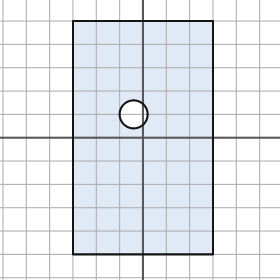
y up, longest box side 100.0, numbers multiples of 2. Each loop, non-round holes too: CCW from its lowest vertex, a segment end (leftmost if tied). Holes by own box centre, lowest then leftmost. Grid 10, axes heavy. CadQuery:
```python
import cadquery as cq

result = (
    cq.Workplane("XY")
    .moveTo(-30.0, -50.0)
    .lineTo(30.0, -50.0)
    .lineTo(30.0, 50.0)
    .lineTo(-30.0, 50.0)
    .close()
    .moveTo(-4.0, 10.0)
    .circle(6.0)
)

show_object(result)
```